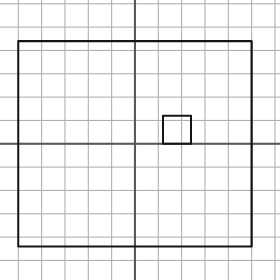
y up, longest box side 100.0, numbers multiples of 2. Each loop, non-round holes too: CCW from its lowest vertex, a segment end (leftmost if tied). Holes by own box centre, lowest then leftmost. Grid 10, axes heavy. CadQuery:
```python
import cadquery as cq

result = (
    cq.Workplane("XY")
    .moveTo(-50.0, -44.0)
    .lineTo(50.0, -44.0)
    .lineTo(50.0, 44.0)
    .lineTo(-50.0, 44.0)
    .close()
    .moveTo(12.0, 0.0)
    .lineTo(24.0, 0.0)
    .lineTo(24.0, 12.0)
    .lineTo(12.0, 12.0)
    .close()
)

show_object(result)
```